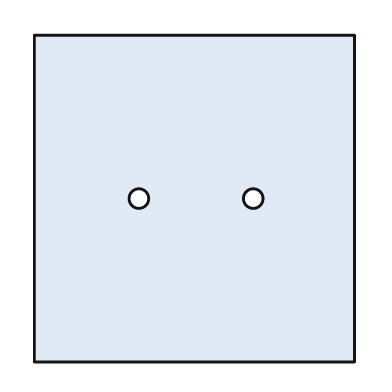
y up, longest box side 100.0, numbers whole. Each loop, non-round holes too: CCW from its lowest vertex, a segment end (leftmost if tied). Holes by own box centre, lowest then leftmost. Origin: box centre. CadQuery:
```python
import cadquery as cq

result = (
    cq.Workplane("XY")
    .moveTo(-49.0, -50.0)
    .lineTo(49.0, -50.0)
    .lineTo(49.0, 50.0)
    .lineTo(-49.0, 50.0)
    .close()
    .moveTo(-17.0, 0.0)
    .circle(3.0)
    .moveTo(18.0, 0.0)
    .circle(3.0)
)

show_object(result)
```